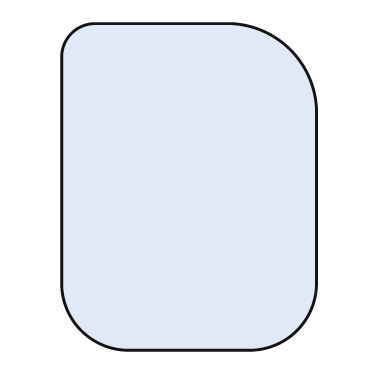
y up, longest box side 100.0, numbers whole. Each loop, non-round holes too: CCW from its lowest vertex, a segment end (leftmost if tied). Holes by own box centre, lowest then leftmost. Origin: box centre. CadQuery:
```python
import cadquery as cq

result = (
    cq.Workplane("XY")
    .moveTo(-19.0, -50.0)
    .lineTo(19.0, -50.0)
    .threePointArc((33.0, -44.0), (39.0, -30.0))
    .lineTo(39.0, 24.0)
    .threePointArc((31.0, 42.0), (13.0, 50.0))
    .lineTo(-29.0, 50.0)
    .threePointArc((-36.0, 47.0), (-39.0, 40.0))
    .lineTo(-39.0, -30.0)
    .threePointArc((-33.0, -44.0), (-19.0, -50.0))
    .close()
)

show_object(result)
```